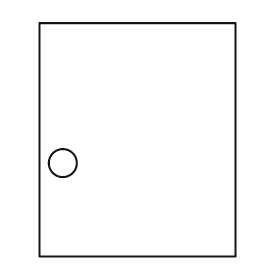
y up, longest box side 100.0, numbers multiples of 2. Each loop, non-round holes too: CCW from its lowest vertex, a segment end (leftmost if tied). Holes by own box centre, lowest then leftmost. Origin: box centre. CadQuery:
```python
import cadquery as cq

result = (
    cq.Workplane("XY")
    .moveTo(-42.0, -50.0)
    .lineTo(42.0, -50.0)
    .lineTo(42.0, 50.0)
    .lineTo(-42.0, 50.0)
    .close()
    .moveTo(-32.0, -10.0)
    .circle(6.0)
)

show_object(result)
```